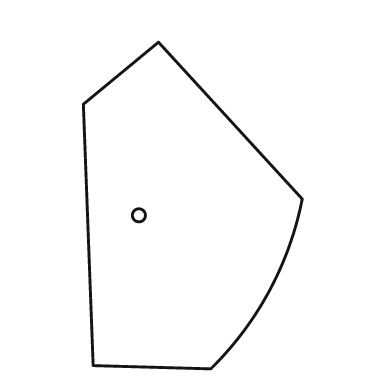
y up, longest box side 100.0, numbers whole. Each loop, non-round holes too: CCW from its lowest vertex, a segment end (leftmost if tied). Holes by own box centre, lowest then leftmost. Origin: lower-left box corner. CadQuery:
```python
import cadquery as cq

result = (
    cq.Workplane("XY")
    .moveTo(39.0, 0.0)
    .threePointArc((57.0, 24.0), (67.0, 52.0))
    .lineTo(23.0, 100.0)
    .lineTo(0.0, 81.0)
    .lineTo(3.0, 1.0)
    .close()
    .moveTo(17.0, 47.0)
    .circle(2.0)
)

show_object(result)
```